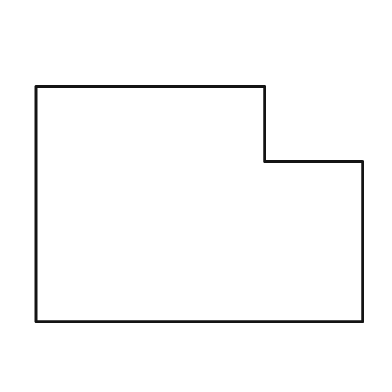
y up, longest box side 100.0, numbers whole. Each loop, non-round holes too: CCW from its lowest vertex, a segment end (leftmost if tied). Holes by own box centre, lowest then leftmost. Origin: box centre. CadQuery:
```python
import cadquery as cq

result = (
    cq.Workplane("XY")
    .moveTo(-50.0, -36.0)
    .lineTo(50.0, -36.0)
    .lineTo(50.0, 13.0)
    .lineTo(20.0, 13.0)
    .lineTo(20.0, 36.0)
    .lineTo(-50.0, 36.0)
    .close()
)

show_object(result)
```